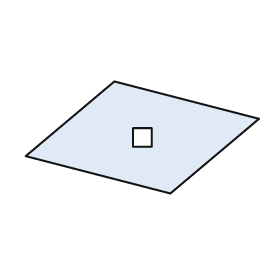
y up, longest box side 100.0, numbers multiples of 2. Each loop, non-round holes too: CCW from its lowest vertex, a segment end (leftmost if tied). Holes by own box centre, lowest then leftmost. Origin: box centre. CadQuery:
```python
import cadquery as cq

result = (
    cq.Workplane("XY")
    .moveTo(12.0, -24.0)
    .lineTo(50.0, 8.0)
    .lineTo(-12.0, 24.0)
    .lineTo(-50.0, -8.0)
    .close()
    .moveTo(-4.0, -4.0)
    .lineTo(4.0, -4.0)
    .lineTo(4.0, 4.0)
    .lineTo(-4.0, 4.0)
    .close()
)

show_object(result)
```